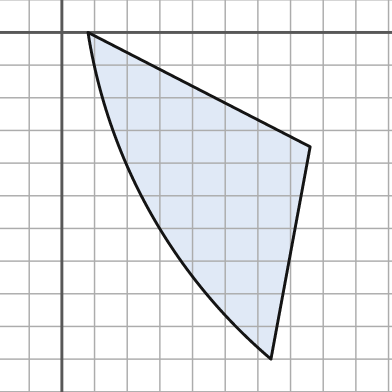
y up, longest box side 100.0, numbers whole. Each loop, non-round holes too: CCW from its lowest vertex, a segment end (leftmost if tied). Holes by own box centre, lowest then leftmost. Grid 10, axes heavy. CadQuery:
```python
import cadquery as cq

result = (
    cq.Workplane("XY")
    .moveTo(64.0, -100.0)
    .lineTo(76.0, -35.0)
    .lineTo(8.0, 0.0)
    .threePointArc((27.0, -55.0), (64.0, -100.0))
    .close()
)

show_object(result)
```